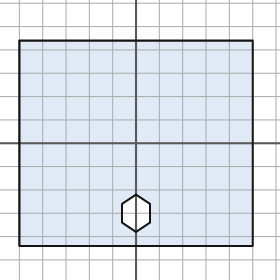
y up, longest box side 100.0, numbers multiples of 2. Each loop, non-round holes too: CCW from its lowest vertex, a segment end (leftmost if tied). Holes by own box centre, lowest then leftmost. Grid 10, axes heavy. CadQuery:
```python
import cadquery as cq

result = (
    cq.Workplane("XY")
    .moveTo(-50.0, -44.0)
    .lineTo(50.0, -44.0)
    .lineTo(50.0, 44.0)
    .lineTo(-50.0, 44.0)
    .close()
    .moveTo(0.0, -38.0)
    .lineTo(6.0, -34.0)
    .lineTo(6.0, -26.0)
    .lineTo(0.0, -22.0)
    .lineTo(-6.0, -26.0)
    .lineTo(-6.0, -34.0)
    .close()
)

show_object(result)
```